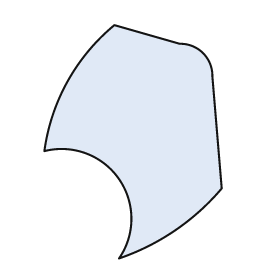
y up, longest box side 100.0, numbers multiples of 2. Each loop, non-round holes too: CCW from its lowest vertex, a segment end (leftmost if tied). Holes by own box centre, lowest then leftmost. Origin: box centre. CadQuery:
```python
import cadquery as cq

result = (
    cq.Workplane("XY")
    .moveTo(-6.0, -50.0)
    .threePointArc((18.0, -38.0), (38.0, -20.0))
    .lineTo(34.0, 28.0)
    .threePointArc((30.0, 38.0), (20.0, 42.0))
    .lineTo(-8.0, 50.0)
    .threePointArc((-28.0, 26.0), (-38.0, -4.0))
    .threePointArc((-6.0, -16.0), (-6.0, -50.0))
    .close()
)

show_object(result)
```